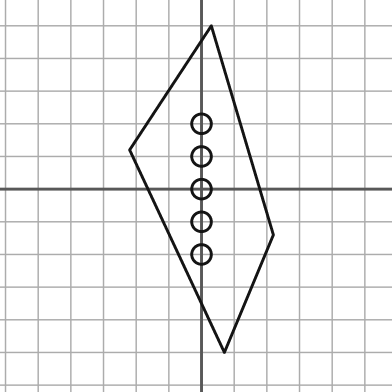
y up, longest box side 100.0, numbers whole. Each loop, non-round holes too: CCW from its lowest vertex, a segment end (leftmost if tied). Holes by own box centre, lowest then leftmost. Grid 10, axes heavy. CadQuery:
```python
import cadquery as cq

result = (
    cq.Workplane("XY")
    .moveTo(7.0, -50.0)
    .lineTo(22.0, -14.0)
    .lineTo(3.0, 50.0)
    .lineTo(-22.0, 12.0)
    .close()
    .moveTo(0.0, -20.0)
    .circle(3.0)
    .moveTo(0.0, -10.0)
    .circle(3.0)
    .moveTo(0.0, 0.0)
    .circle(3.0)
    .moveTo(0.0, 10.0)
    .circle(3.0)
    .moveTo(0.0, 20.0)
    .circle(3.0)
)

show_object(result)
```